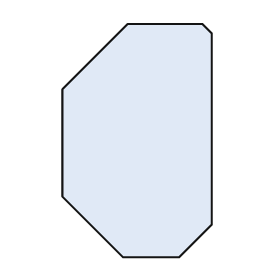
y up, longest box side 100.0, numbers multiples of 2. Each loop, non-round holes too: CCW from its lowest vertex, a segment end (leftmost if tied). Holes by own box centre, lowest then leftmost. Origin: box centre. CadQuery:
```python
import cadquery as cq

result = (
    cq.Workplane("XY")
    .moveTo(-6.0, -50.0)
    .lineTo(18.0, -50.0)
    .lineTo(32.0, -36.0)
    .lineTo(32.0, 46.0)
    .lineTo(28.0, 50.0)
    .lineTo(-4.0, 50.0)
    .lineTo(-32.0, 22.0)
    .lineTo(-32.0, -24.0)
    .close()
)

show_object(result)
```